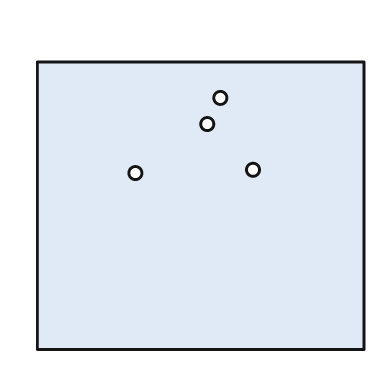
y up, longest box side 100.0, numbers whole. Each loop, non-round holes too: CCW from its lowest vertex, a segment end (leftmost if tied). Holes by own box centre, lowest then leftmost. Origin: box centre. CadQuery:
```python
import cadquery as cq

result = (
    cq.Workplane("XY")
    .moveTo(-50.0, -44.0)
    .lineTo(50.0, -44.0)
    .lineTo(50.0, 44.0)
    .lineTo(-50.0, 44.0)
    .close()
    .moveTo(-20.0, 10.0)
    .circle(2.0)
    .moveTo(16.0, 11.0)
    .circle(2.0)
    .moveTo(2.0, 25.0)
    .circle(2.0)
    .moveTo(6.0, 33.0)
    .circle(2.0)
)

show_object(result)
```